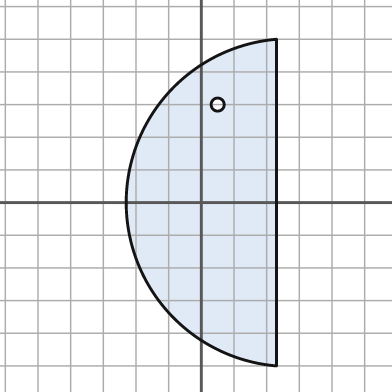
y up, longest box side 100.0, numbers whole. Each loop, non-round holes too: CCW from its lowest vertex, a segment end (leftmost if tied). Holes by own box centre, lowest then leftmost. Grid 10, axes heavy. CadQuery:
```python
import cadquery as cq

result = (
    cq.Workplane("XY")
    .moveTo(23.0, -50.0)
    .lineTo(23.0, 50.0)
    .threePointArc((-23.0, 0.0), (23.0, -50.0))
    .close()
    .moveTo(5.0, 30.0)
    .circle(2.0)
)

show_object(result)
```